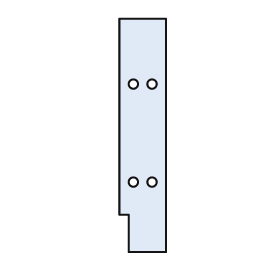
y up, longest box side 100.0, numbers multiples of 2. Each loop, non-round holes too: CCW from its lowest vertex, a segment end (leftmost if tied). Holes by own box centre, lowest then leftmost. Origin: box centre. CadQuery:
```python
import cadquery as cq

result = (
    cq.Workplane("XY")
    .moveTo(-6.0, -50.0)
    .lineTo(10.0, -50.0)
    .lineTo(10.0, 50.0)
    .lineTo(-10.0, 50.0)
    .lineTo(-10.0, -34.0)
    .lineTo(-6.0, -34.0)
    .close()
    .moveTo(-4.0, -20.0)
    .circle(2.0)
    .moveTo(4.0, -20.0)
    .circle(2.0)
    .moveTo(-4.0, 22.0)
    .circle(2.0)
    .moveTo(4.0, 22.0)
    .circle(2.0)
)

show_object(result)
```